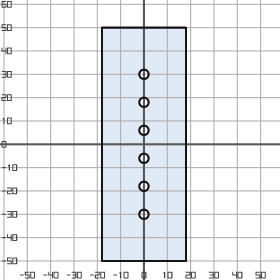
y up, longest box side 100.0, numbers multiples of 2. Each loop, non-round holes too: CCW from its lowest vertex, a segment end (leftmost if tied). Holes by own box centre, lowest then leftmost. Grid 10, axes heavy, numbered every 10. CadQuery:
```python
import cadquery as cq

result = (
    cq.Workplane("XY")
    .moveTo(-18.0, -50.0)
    .lineTo(18.0, -50.0)
    .lineTo(18.0, 50.0)
    .lineTo(-18.0, 50.0)
    .close()
    .moveTo(0.0, -30.0)
    .circle(2.0)
    .moveTo(0.0, -18.0)
    .circle(2.0)
    .moveTo(0.0, -6.0)
    .circle(2.0)
    .moveTo(0.0, 6.0)
    .circle(2.0)
    .moveTo(0.0, 18.0)
    .circle(2.0)
    .moveTo(0.0, 30.0)
    .circle(2.0)
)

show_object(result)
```